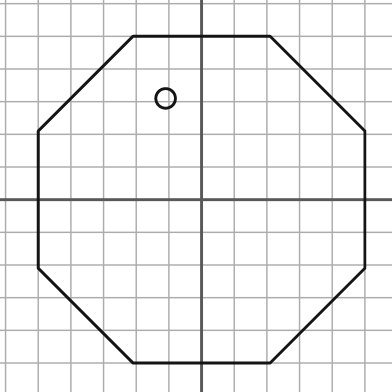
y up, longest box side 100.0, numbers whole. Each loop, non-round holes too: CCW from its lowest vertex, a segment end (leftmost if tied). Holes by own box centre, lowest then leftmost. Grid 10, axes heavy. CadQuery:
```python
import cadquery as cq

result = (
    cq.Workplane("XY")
    .moveTo(-21.0, -50.0)
    .lineTo(21.0, -50.0)
    .lineTo(50.0, -21.0)
    .lineTo(50.0, 21.0)
    .lineTo(21.0, 50.0)
    .lineTo(-21.0, 50.0)
    .lineTo(-50.0, 21.0)
    .lineTo(-50.0, -21.0)
    .close()
    .moveTo(-11.0, 31.0)
    .circle(3.0)
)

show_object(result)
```